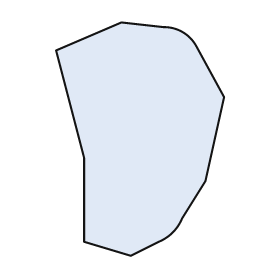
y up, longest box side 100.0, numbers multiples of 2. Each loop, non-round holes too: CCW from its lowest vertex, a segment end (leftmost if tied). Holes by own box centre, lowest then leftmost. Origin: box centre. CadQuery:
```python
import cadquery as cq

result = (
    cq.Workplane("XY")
    .moveTo(-4.0, -50.0)
    .lineTo(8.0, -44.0)
    .threePointArc((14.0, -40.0), (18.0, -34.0))
    .lineTo(28.0, -18.0)
    .lineTo(36.0, 18.0)
    .lineTo(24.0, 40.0)
    .threePointArc((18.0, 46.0), (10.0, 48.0))
    .lineTo(-8.0, 50.0)
    .lineTo(-36.0, 38.0)
    .lineTo(-24.0, -8.0)
    .lineTo(-24.0, -44.0)
    .close()
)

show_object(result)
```